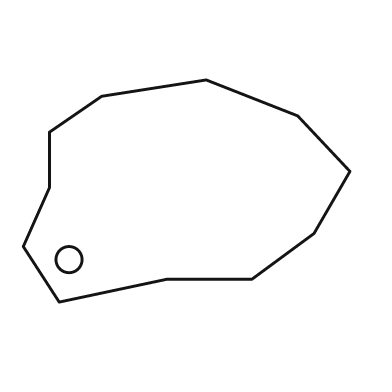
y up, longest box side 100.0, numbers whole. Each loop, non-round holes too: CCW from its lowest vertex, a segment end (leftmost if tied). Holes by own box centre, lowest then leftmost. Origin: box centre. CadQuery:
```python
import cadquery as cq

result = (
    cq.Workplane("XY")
    .moveTo(-39.0, -34.0)
    .lineTo(-6.0, -27.0)
    .lineTo(20.0, -27.0)
    .lineTo(39.0, -13.0)
    .lineTo(50.0, 6.0)
    .lineTo(34.0, 23.0)
    .lineTo(6.0, 34.0)
    .lineTo(-26.0, 29.0)
    .lineTo(-42.0, 18.0)
    .lineTo(-42.0, 1.0)
    .lineTo(-50.0, -17.0)
    .close()
    .moveTo(-36.0, -21.0)
    .circle(4.0)
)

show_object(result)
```